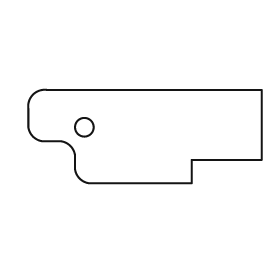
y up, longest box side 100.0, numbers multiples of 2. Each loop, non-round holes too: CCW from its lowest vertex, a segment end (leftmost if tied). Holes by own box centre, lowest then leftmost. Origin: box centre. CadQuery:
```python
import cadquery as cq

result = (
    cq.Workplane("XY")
    .moveTo(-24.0, -20.0)
    .lineTo(20.0, -20.0)
    .lineTo(20.0, -10.0)
    .lineTo(50.0, -10.0)
    .lineTo(50.0, 20.0)
    .lineTo(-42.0, 20.0)
    .threePointArc((-48.0, 18.0), (-50.0, 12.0))
    .lineTo(-50.0, 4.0)
    .threePointArc((-48.0, 0.0), (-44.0, -2.0))
    .lineTo(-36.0, -2.0)
    .threePointArc((-32.0, -4.0), (-30.0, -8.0))
    .lineTo(-30.0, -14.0)
    .threePointArc((-28.0, -18.0), (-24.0, -20.0))
    .close()
    .moveTo(-26.0, 4.0)
    .circle(4.0)
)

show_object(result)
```